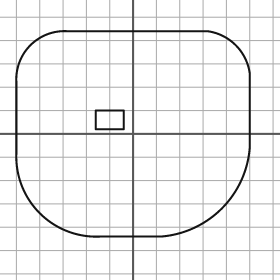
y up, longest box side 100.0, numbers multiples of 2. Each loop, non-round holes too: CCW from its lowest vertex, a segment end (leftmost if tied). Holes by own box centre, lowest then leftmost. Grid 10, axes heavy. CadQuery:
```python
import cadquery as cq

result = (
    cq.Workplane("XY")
    .moveTo(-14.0, -44.0)
    .lineTo(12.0, -44.0)
    .threePointArc((38.0, -32.0), (50.0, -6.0))
    .lineTo(50.0, 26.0)
    .threePointArc((44.0, 38.0), (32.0, 44.0))
    .lineTo(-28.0, 44.0)
    .threePointArc((-44.0, 38.0), (-50.0, 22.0))
    .lineTo(-50.0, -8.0)
    .threePointArc((-40.0, -34.0), (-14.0, -44.0))
    .close()
    .moveTo(-16.0, 2.0)
    .lineTo(-4.0, 2.0)
    .lineTo(-4.0, 10.0)
    .lineTo(-16.0, 10.0)
    .close()
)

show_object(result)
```